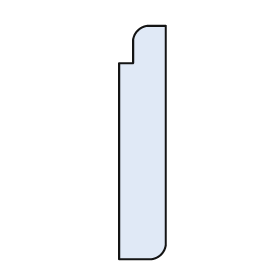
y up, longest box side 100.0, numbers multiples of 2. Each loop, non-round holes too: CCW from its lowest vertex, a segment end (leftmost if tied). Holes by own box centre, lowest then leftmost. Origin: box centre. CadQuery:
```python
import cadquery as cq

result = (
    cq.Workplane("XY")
    .moveTo(-10.0, -50.0)
    .lineTo(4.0, -50.0)
    .threePointArc((8.0, -48.0), (10.0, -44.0))
    .lineTo(10.0, 50.0)
    .lineTo(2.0, 50.0)
    .threePointArc((-2.0, 48.0), (-4.0, 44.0))
    .lineTo(-4.0, 34.0)
    .lineTo(-10.0, 34.0)
    .close()
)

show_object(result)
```